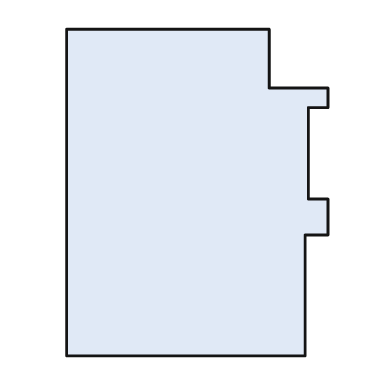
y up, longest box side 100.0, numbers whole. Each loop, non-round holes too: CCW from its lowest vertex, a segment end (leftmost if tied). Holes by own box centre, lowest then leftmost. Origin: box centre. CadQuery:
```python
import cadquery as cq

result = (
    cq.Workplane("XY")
    .moveTo(-40.0, -50.0)
    .lineTo(33.0, -50.0)
    .lineTo(33.0, -13.0)
    .lineTo(40.0, -13.0)
    .lineTo(40.0, -2.0)
    .lineTo(34.0, -2.0)
    .lineTo(34.0, 26.0)
    .lineTo(40.0, 26.0)
    .lineTo(40.0, 32.0)
    .lineTo(22.0, 32.0)
    .lineTo(22.0, 50.0)
    .lineTo(-40.0, 50.0)
    .close()
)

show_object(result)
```